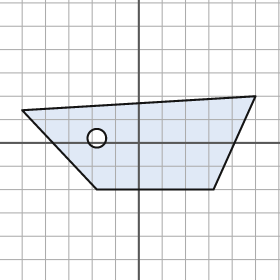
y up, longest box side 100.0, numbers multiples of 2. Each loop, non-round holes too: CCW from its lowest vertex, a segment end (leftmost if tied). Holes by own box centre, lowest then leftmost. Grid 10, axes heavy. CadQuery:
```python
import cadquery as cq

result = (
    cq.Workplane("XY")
    .moveTo(-18.0, -20.0)
    .lineTo(32.0, -20.0)
    .lineTo(50.0, 20.0)
    .lineTo(-50.0, 14.0)
    .close()
    .moveTo(-18.0, 2.0)
    .circle(4.0)
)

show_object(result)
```